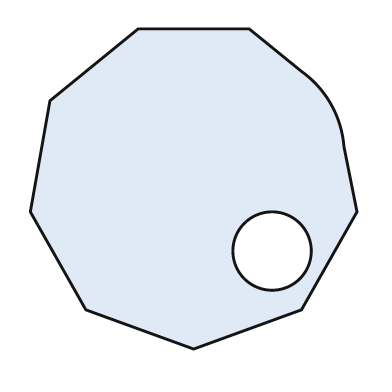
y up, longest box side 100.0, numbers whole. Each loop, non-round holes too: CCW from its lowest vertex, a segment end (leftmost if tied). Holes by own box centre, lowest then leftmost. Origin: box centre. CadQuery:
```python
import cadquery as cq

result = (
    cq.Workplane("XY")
    .moveTo(0.0, -49.0)
    .lineTo(33.0, -37.0)
    .lineTo(50.0, -7.0)
    .lineTo(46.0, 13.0)
    .threePointArc((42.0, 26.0), (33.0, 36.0))
    .lineTo(17.0, 49.0)
    .lineTo(-17.0, 49.0)
    .lineTo(-44.0, 27.0)
    .lineTo(-50.0, -7.0)
    .lineTo(-33.0, -37.0)
    .close()
    .moveTo(24.0, -19.0)
    .circle(12.0)
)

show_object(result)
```